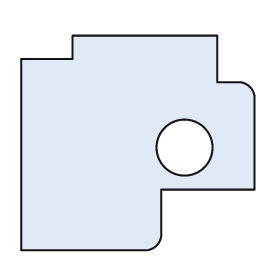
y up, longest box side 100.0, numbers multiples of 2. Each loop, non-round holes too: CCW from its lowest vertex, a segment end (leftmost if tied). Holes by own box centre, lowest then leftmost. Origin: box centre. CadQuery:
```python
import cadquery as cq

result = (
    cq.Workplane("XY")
    .moveTo(-50.0, -46.0)
    .lineTo(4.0, -46.0)
    .threePointArc((8.0, -44.0), (10.0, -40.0))
    .lineTo(10.0, -20.0)
    .lineTo(50.0, -20.0)
    .lineTo(50.0, 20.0)
    .threePointArc((48.0, 24.0), (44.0, 26.0))
    .lineTo(34.0, 26.0)
    .lineTo(34.0, 46.0)
    .lineTo(-28.0, 46.0)
    .lineTo(-28.0, 36.0)
    .lineTo(-50.0, 36.0)
    .close()
    .moveTo(20.0, -2.0)
    .circle(12.0)
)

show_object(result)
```